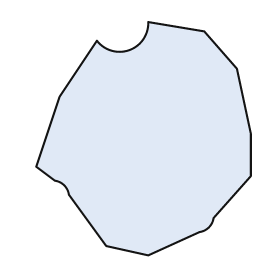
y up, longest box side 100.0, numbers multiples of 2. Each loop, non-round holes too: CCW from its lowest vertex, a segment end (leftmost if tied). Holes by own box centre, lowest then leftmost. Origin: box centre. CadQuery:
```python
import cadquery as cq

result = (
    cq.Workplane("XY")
    .moveTo(2.0, -50.0)
    .lineTo(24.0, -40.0)
    .threePointArc((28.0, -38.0), (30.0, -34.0))
    .lineTo(46.0, -16.0)
    .lineTo(46.0, 2.0)
    .lineTo(40.0, 30.0)
    .lineTo(26.0, 46.0)
    .lineTo(2.0, 50.0)
    .threePointArc((-6.0, 38.0), (-20.0, 42.0))
    .lineTo(-36.0, 18.0)
    .lineTo(-46.0, -12.0)
    .lineTo(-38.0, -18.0)
    .threePointArc((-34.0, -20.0), (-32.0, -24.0))
    .lineTo(-16.0, -46.0)
    .close()
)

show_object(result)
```